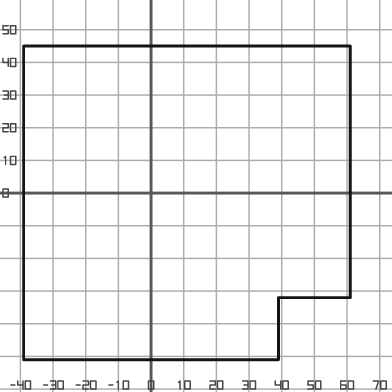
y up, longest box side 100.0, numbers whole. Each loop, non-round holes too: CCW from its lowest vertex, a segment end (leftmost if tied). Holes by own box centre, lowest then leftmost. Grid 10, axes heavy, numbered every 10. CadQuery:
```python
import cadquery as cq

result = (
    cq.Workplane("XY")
    .moveTo(-39.0, -51.0)
    .lineTo(39.0, -51.0)
    .lineTo(39.0, -32.0)
    .lineTo(61.0, -32.0)
    .lineTo(61.0, 45.0)
    .lineTo(-39.0, 45.0)
    .close()
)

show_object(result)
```